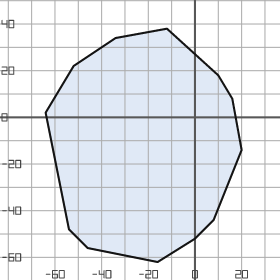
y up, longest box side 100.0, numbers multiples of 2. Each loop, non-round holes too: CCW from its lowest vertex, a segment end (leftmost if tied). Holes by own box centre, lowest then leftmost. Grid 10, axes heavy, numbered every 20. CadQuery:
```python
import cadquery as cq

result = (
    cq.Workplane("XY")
    .moveTo(-16.0, -62.0)
    .lineTo(0.0, -52.0)
    .lineTo(8.0, -44.0)
    .lineTo(20.0, -14.0)
    .lineTo(16.0, 8.0)
    .lineTo(10.0, 18.0)
    .lineTo(-12.0, 38.0)
    .lineTo(-34.0, 34.0)
    .lineTo(-52.0, 22.0)
    .lineTo(-64.0, 2.0)
    .lineTo(-54.0, -48.0)
    .lineTo(-46.0, -56.0)
    .close()
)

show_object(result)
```